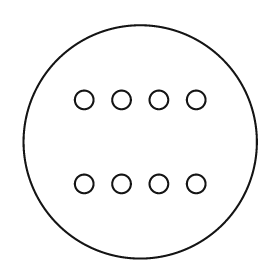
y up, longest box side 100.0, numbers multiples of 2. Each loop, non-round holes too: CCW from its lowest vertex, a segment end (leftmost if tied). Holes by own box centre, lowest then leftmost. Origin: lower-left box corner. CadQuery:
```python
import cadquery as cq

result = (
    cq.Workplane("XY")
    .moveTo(50.0, 50.0)
    .circle(50.0)
    .moveTo(26.0, 32.0)
    .circle(4.0)
    .moveTo(42.0, 32.0)
    .circle(4.0)
    .moveTo(58.0, 32.0)
    .circle(4.0)
    .moveTo(74.0, 32.0)
    .circle(4.0)
    .moveTo(26.0, 68.0)
    .circle(4.0)
    .moveTo(42.0, 68.0)
    .circle(4.0)
    .moveTo(58.0, 68.0)
    .circle(4.0)
    .moveTo(74.0, 68.0)
    .circle(4.0)
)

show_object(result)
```